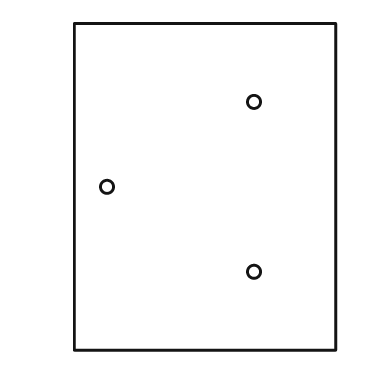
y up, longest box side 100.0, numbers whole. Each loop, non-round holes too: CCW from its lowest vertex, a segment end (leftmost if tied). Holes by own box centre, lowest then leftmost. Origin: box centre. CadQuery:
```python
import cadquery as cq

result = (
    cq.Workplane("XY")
    .moveTo(-40.0, -50.0)
    .lineTo(40.0, -50.0)
    .lineTo(40.0, 50.0)
    .lineTo(-40.0, 50.0)
    .close()
    .moveTo(15.0, -26.0)
    .circle(2.0)
    .moveTo(-30.0, 0.0)
    .circle(2.0)
    .moveTo(15.0, 26.0)
    .circle(2.0)
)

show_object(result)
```